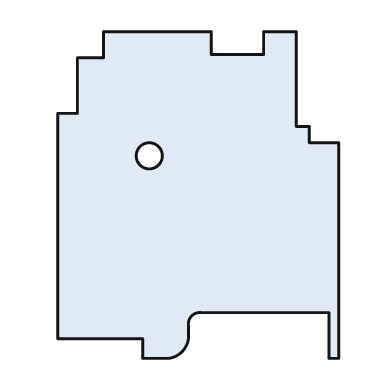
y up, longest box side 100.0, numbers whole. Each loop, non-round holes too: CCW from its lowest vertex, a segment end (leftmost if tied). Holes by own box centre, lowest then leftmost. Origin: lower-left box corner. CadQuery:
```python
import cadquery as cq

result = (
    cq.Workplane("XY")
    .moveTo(26.0, 0.0)
    .lineTo(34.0, 0.0)
    .threePointArc((38.0, 2.0), (40.0, 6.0))
    .lineTo(40.0, 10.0)
    .threePointArc((41.0, 13.0), (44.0, 14.0))
    .lineTo(83.0, 14.0)
    .lineTo(83.0, 0.0)
    .lineTo(86.0, 0.0)
    .lineTo(86.0, 66.0)
    .lineTo(77.0, 66.0)
    .lineTo(77.0, 71.0)
    .lineTo(73.0, 71.0)
    .lineTo(73.0, 100.0)
    .lineTo(63.0, 100.0)
    .lineTo(63.0, 93.0)
    .lineTo(47.0, 93.0)
    .lineTo(47.0, 100.0)
    .lineTo(14.0, 100.0)
    .lineTo(14.0, 92.0)
    .lineTo(6.0, 92.0)
    .lineTo(6.0, 75.0)
    .lineTo(0.0, 75.0)
    .lineTo(0.0, 6.0)
    .lineTo(26.0, 6.0)
    .close()
    .moveTo(28.0, 62.0)
    .circle(4.0)
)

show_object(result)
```